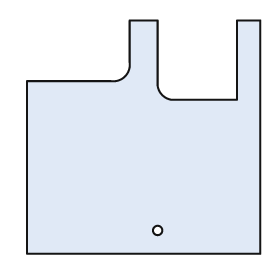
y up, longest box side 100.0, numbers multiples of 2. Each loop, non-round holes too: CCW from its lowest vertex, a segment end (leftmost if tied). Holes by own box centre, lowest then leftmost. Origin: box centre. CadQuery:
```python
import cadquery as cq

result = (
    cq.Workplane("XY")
    .moveTo(-50.0, -50.0)
    .lineTo(50.0, -50.0)
    .lineTo(50.0, 50.0)
    .lineTo(40.0, 50.0)
    .lineTo(40.0, 16.0)
    .lineTo(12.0, 16.0)
    .threePointArc((8.0, 18.0), (6.0, 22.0))
    .lineTo(6.0, 50.0)
    .lineTo(-6.0, 50.0)
    .lineTo(-6.0, 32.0)
    .threePointArc((-8.0, 26.0), (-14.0, 24.0))
    .lineTo(-50.0, 24.0)
    .close()
    .moveTo(6.0, -40.0)
    .circle(2.0)
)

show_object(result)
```